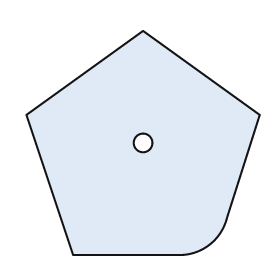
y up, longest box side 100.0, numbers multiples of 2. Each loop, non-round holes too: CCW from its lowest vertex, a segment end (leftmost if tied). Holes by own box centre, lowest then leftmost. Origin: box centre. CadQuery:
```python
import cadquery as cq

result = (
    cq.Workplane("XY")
    .moveTo(-30.0, -48.0)
    .lineTo(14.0, -48.0)
    .threePointArc((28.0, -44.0), (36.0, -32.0))
    .lineTo(50.0, 12.0)
    .lineTo(0.0, 48.0)
    .lineTo(-50.0, 12.0)
    .close()
    .moveTo(0.0, 0.0)
    .circle(4.0)
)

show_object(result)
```